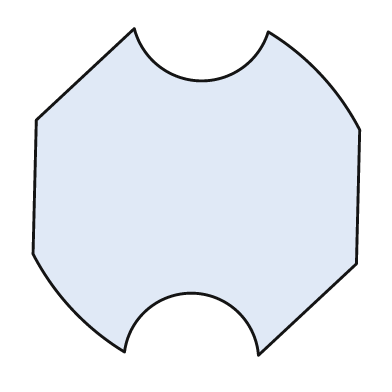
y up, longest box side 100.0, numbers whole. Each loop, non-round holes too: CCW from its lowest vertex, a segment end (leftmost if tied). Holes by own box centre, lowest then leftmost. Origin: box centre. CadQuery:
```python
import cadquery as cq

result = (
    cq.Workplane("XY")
    .moveTo(19.0, -50.0)
    .lineTo(49.0, -22.0)
    .lineTo(50.0, 19.0)
    .threePointArc((38.0, 36.0), (22.0, 49.0))
    .threePointArc((1.0, 34.0), (-19.0, 50.0))
    .lineTo(-49.0, 22.0)
    .lineTo(-50.0, -19.0)
    .threePointArc((-38.0, -36.0), (-22.0, -49.0))
    .threePointArc((-1.0, -31.0), (19.0, -50.0))
    .close()
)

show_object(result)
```